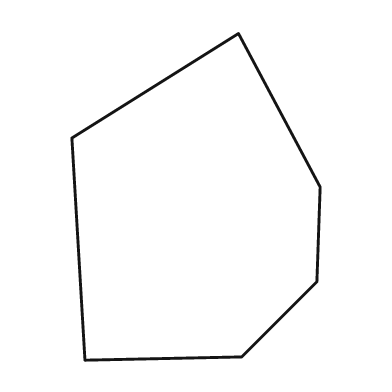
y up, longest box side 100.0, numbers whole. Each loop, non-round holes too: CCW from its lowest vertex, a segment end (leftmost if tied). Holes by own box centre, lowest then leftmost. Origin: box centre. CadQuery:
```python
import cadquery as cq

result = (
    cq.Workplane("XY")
    .moveTo(-34.0, -50.0)
    .lineTo(14.0, -49.0)
    .lineTo(37.0, -26.0)
    .lineTo(38.0, 3.0)
    .lineTo(13.0, 50.0)
    .lineTo(-38.0, 18.0)
    .close()
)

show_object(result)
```